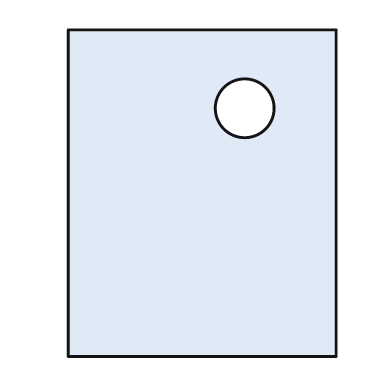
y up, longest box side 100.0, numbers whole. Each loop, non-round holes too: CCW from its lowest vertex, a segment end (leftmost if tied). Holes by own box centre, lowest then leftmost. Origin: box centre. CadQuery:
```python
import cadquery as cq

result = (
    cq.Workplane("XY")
    .moveTo(-41.0, -50.0)
    .lineTo(41.0, -50.0)
    .lineTo(41.0, 50.0)
    .lineTo(-41.0, 50.0)
    .close()
    .moveTo(13.0, 26.0)
    .circle(9.0)
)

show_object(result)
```